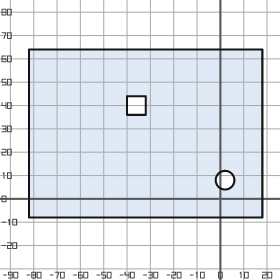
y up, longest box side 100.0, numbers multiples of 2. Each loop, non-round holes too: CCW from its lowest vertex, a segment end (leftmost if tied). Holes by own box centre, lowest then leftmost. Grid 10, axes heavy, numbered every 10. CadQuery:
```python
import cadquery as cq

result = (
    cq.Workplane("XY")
    .moveTo(-82.0, -8.0)
    .lineTo(18.0, -8.0)
    .lineTo(18.0, 64.0)
    .lineTo(-82.0, 64.0)
    .close()
    .moveTo(2.0, 8.0)
    .circle(4.0)
    .moveTo(-40.0, 36.0)
    .lineTo(-32.0, 36.0)
    .lineTo(-32.0, 44.0)
    .lineTo(-40.0, 44.0)
    .close()
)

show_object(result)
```